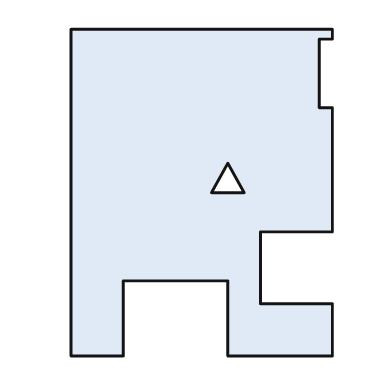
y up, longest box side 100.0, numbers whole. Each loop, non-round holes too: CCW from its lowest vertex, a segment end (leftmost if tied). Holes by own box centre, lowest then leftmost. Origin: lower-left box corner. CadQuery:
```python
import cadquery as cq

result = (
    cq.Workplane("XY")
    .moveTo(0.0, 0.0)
    .lineTo(16.0, 0.0)
    .lineTo(16.0, 23.0)
    .lineTo(48.0, 23.0)
    .lineTo(48.0, 0.0)
    .lineTo(80.0, 0.0)
    .lineTo(80.0, 16.0)
    .lineTo(58.0, 16.0)
    .lineTo(58.0, 38.0)
    .lineTo(80.0, 38.0)
    .lineTo(80.0, 76.0)
    .lineTo(76.0, 76.0)
    .lineTo(76.0, 97.0)
    .lineTo(80.0, 97.0)
    .lineTo(80.0, 100.0)
    .lineTo(0.0, 100.0)
    .close()
    .moveTo(43.0, 50.0)
    .lineTo(53.0, 50.0)
    .lineTo(48.0, 59.0)
    .close()
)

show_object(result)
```